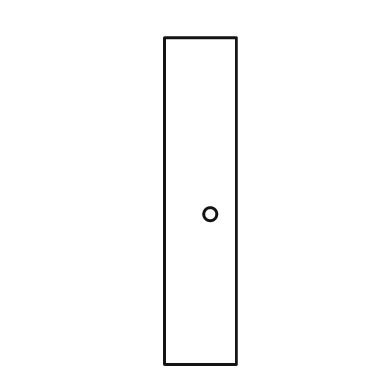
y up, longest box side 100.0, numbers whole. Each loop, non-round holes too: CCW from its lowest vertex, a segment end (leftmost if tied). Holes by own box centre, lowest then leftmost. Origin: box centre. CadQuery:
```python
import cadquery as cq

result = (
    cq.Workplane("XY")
    .moveTo(-11.0, -50.0)
    .lineTo(11.0, -50.0)
    .lineTo(11.0, 50.0)
    .lineTo(-11.0, 50.0)
    .close()
    .moveTo(3.0, -4.0)
    .circle(2.0)
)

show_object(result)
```